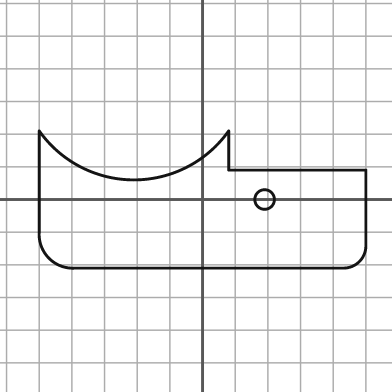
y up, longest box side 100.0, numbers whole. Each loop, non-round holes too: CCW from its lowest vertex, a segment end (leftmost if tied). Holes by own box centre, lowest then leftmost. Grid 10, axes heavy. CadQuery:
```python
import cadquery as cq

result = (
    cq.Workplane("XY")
    .moveTo(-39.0, -21.0)
    .lineTo(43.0, -21.0)
    .threePointArc((48.0, -19.0), (50.0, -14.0))
    .lineTo(50.0, 9.0)
    .lineTo(8.0, 9.0)
    .lineTo(8.0, 21.0)
    .threePointArc((-21.0, 6.0), (-50.0, 21.0))
    .lineTo(-50.0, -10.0)
    .threePointArc((-47.0, -18.0), (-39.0, -21.0))
    .close()
    .moveTo(19.0, 0.0)
    .circle(3.0)
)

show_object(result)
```